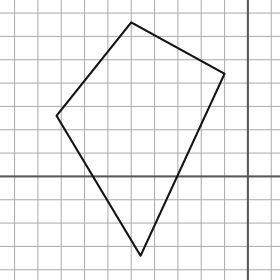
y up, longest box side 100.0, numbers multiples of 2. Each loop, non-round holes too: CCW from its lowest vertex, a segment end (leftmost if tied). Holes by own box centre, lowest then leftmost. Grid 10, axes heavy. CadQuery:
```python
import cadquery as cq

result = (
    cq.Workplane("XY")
    .moveTo(-46.0, -34.0)
    .lineTo(-10.0, 44.0)
    .lineTo(-50.0, 66.0)
    .lineTo(-82.0, 26.0)
    .close()
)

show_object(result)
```